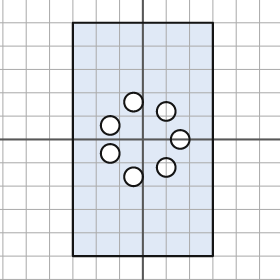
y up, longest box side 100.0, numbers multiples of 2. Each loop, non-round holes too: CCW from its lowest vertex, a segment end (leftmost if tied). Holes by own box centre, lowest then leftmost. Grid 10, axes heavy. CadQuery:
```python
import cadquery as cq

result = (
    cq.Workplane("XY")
    .moveTo(-30.0, -50.0)
    .lineTo(30.0, -50.0)
    .lineTo(30.0, 50.0)
    .lineTo(-30.0, 50.0)
    .close()
    .moveTo(-4.0, -16.0)
    .circle(4.0)
    .moveTo(10.0, -12.0)
    .circle(4.0)
    .moveTo(-14.0, -6.0)
    .circle(4.0)
    .moveTo(16.0, 0.0)
    .circle(4.0)
    .moveTo(-14.0, 6.0)
    .circle(4.0)
    .moveTo(10.0, 12.0)
    .circle(4.0)
    .moveTo(-4.0, 16.0)
    .circle(4.0)
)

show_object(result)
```